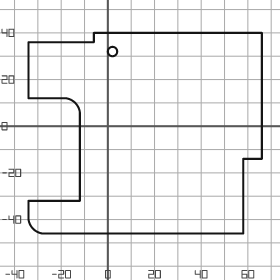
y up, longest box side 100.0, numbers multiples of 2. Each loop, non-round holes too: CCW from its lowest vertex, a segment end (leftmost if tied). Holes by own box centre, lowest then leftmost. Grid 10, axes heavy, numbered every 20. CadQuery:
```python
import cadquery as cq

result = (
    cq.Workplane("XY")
    .moveTo(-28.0, -46.0)
    .lineTo(58.0, -46.0)
    .lineTo(58.0, -14.0)
    .lineTo(66.0, -14.0)
    .lineTo(66.0, 40.0)
    .lineTo(-6.0, 40.0)
    .lineTo(-6.0, 36.0)
    .lineTo(-34.0, 36.0)
    .lineTo(-34.0, 12.0)
    .lineTo(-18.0, 12.0)
    .threePointArc((-14.0, 10.0), (-12.0, 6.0))
    .lineTo(-12.0, -32.0)
    .lineTo(-34.0, -32.0)
    .lineTo(-34.0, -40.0)
    .threePointArc((-32.0, -44.0), (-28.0, -46.0))
    .close()
    .moveTo(2.0, 32.0)
    .circle(2.0)
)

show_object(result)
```